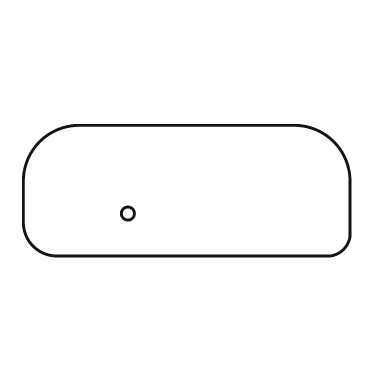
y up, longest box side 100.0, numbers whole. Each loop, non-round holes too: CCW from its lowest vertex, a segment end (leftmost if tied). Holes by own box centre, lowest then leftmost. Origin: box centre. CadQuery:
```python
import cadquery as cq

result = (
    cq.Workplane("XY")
    .moveTo(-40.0, -20.0)
    .lineTo(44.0, -20.0)
    .threePointArc((48.0, -18.0), (50.0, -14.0))
    .lineTo(50.0, 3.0)
    .threePointArc((45.0, 15.0), (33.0, 20.0))
    .lineTo(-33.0, 20.0)
    .threePointArc((-45.0, 15.0), (-50.0, 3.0))
    .lineTo(-50.0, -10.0)
    .threePointArc((-47.0, -17.0), (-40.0, -20.0))
    .close()
    .moveTo(-18.0, -7.0)
    .circle(2.0)
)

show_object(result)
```